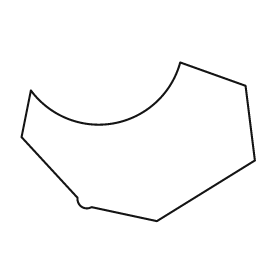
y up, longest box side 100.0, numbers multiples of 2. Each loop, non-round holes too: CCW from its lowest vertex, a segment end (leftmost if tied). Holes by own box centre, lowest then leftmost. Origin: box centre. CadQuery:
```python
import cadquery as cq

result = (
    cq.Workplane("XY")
    .moveTo(8.0, -34.0)
    .lineTo(50.0, -8.0)
    .lineTo(46.0, 24.0)
    .lineTo(18.0, 34.0)
    .threePointArc((-10.0, 8.0), (-46.0, 22.0))
    .lineTo(-50.0, 2.0)
    .lineTo(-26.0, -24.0)
    .threePointArc((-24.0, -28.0), (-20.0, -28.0))
    .close()
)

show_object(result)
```